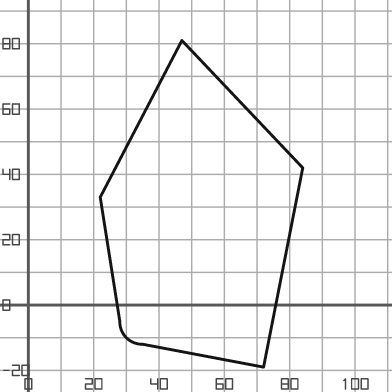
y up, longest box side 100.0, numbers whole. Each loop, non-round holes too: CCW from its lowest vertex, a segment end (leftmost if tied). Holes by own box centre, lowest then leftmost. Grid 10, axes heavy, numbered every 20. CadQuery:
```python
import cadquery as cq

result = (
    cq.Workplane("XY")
    .moveTo(72.0, -19.0)
    .lineTo(84.0, 42.0)
    .lineTo(47.0, 81.0)
    .lineTo(22.0, 33.0)
    .lineTo(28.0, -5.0)
    .threePointArc((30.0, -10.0), (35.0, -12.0))
    .close()
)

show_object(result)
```